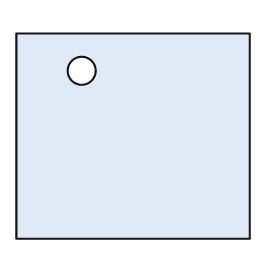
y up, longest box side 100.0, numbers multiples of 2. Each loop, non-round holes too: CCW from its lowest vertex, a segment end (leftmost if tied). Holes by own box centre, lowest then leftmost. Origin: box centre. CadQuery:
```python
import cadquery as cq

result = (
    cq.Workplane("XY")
    .moveTo(-50.0, -44.0)
    .lineTo(50.0, -44.0)
    .lineTo(50.0, 44.0)
    .lineTo(-50.0, 44.0)
    .close()
    .moveTo(-22.0, 28.0)
    .circle(6.0)
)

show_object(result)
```